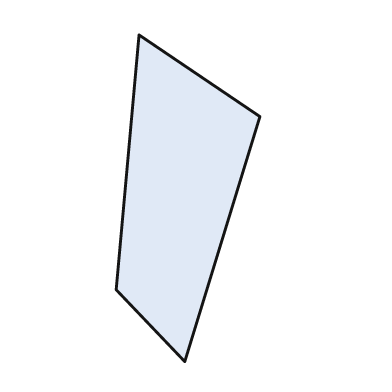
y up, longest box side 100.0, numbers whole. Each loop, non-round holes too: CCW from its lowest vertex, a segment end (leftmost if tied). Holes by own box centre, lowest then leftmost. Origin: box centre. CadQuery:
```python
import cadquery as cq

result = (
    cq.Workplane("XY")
    .moveTo(-1.0, -50.0)
    .lineTo(22.0, 25.0)
    .lineTo(-15.0, 50.0)
    .lineTo(-22.0, -28.0)
    .close()
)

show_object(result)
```